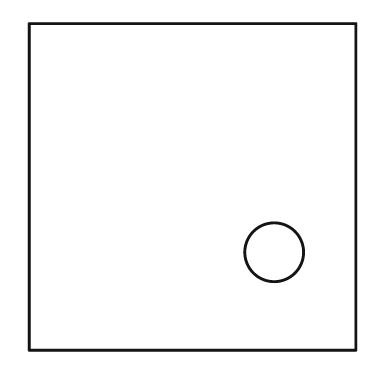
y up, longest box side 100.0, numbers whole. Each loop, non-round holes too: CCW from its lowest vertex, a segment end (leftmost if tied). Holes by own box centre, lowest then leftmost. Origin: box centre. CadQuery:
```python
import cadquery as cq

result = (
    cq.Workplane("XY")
    .moveTo(-50.0, -50.0)
    .lineTo(50.0, -50.0)
    .lineTo(50.0, 50.0)
    .lineTo(-50.0, 50.0)
    .close()
    .moveTo(25.0, -20.0)
    .circle(9.0)
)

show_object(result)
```